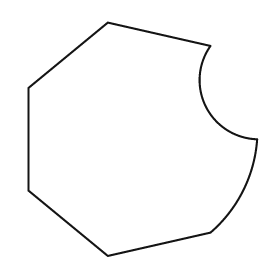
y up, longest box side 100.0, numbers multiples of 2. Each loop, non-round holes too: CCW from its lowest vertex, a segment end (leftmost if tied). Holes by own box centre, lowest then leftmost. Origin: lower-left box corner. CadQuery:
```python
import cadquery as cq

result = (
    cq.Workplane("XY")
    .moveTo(34.0, 0.0)
    .lineTo(78.0, 10.0)
    .threePointArc((92.0, 28.0), (98.0, 50.0))
    .threePointArc((76.0, 64.0), (78.0, 90.0))
    .lineTo(34.0, 100.0)
    .lineTo(0.0, 72.0)
    .lineTo(0.0, 28.0)
    .close()
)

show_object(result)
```